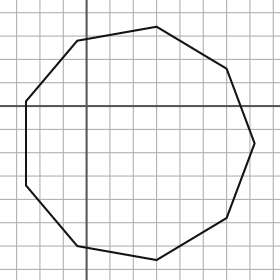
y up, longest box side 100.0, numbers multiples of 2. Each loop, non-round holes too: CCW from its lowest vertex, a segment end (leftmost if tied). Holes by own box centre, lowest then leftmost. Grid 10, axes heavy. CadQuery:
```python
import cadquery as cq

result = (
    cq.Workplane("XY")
    .moveTo(30.0, -66.0)
    .lineTo(60.0, -48.0)
    .lineTo(72.0, -16.0)
    .lineTo(60.0, 16.0)
    .lineTo(30.0, 34.0)
    .lineTo(-4.0, 28.0)
    .lineTo(-26.0, 2.0)
    .lineTo(-26.0, -34.0)
    .lineTo(-4.0, -60.0)
    .close()
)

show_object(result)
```